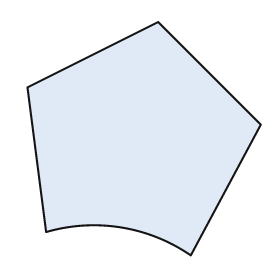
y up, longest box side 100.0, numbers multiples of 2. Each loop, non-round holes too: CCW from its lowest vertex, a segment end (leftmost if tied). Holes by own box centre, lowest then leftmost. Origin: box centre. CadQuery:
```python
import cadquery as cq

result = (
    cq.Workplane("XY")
    .moveTo(20.0, -50.0)
    .lineTo(50.0, 6.0)
    .lineTo(6.0, 50.0)
    .lineTo(-50.0, 22.0)
    .lineTo(-42.0, -40.0)
    .threePointArc((-10.0, -38.0), (20.0, -50.0))
    .close()
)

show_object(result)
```